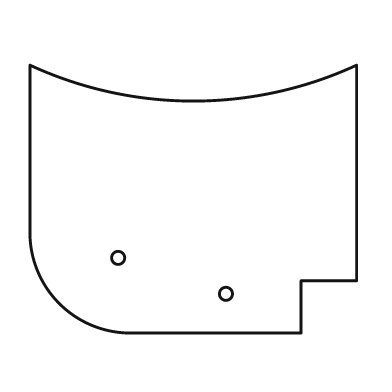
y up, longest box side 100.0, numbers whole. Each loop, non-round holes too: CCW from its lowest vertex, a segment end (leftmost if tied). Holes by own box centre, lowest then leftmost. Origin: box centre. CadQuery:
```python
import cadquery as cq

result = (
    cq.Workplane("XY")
    .moveTo(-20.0, -41.0)
    .lineTo(33.0, -41.0)
    .lineTo(33.0, -25.0)
    .lineTo(50.0, -25.0)
    .lineTo(50.0, 41.0)
    .threePointArc((0.0, 30.0), (-50.0, 41.0))
    .lineTo(-50.0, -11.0)
    .threePointArc((-41.0, -32.0), (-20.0, -41.0))
    .close()
    .moveTo(10.0, -29.0)
    .circle(2.0)
    .moveTo(-23.0, -18.0)
    .circle(2.0)
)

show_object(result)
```